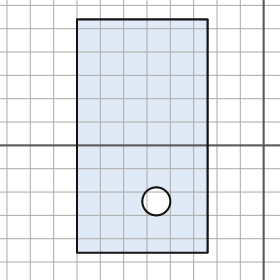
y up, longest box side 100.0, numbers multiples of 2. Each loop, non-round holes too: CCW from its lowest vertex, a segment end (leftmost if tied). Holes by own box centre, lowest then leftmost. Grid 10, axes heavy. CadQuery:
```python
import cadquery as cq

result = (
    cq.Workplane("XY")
    .moveTo(-80.0, -46.0)
    .lineTo(-24.0, -46.0)
    .lineTo(-24.0, 54.0)
    .lineTo(-80.0, 54.0)
    .close()
    .moveTo(-46.0, -24.0)
    .circle(6.0)
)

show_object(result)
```